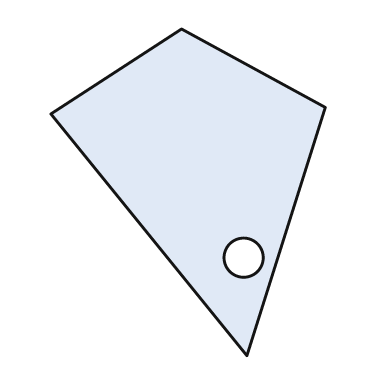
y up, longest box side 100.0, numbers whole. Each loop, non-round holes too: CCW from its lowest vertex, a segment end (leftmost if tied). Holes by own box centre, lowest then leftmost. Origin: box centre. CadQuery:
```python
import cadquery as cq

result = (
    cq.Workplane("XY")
    .moveTo(18.0, -50.0)
    .lineTo(42.0, 26.0)
    .lineTo(-2.0, 50.0)
    .lineTo(-42.0, 24.0)
    .close()
    .moveTo(17.0, -20.0)
    .circle(6.0)
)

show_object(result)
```